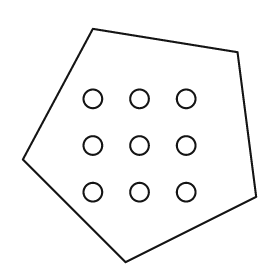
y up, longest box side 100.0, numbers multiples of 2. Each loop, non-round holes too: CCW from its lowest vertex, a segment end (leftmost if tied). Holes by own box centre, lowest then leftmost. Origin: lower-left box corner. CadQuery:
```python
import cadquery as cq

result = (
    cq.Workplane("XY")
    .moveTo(44.0, 0.0)
    .lineTo(100.0, 28.0)
    .lineTo(92.0, 90.0)
    .lineTo(30.0, 100.0)
    .lineTo(0.0, 44.0)
    .close()
    .moveTo(30.0, 30.0)
    .circle(4.0)
    .moveTo(50.0, 30.0)
    .circle(4.0)
    .moveTo(70.0, 30.0)
    .circle(4.0)
    .moveTo(30.0, 50.0)
    .circle(4.0)
    .moveTo(50.0, 50.0)
    .circle(4.0)
    .moveTo(70.0, 50.0)
    .circle(4.0)
    .moveTo(30.0, 70.0)
    .circle(4.0)
    .moveTo(50.0, 70.0)
    .circle(4.0)
    .moveTo(70.0, 70.0)
    .circle(4.0)
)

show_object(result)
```